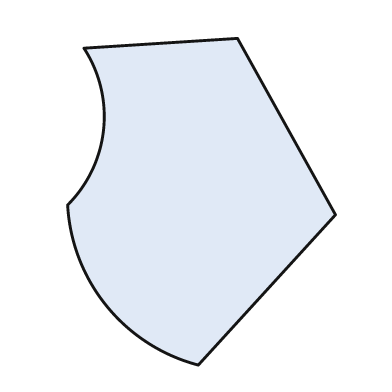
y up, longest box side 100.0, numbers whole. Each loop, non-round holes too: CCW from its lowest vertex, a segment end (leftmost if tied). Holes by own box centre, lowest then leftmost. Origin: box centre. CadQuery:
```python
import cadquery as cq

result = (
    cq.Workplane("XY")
    .moveTo(-1.0, -50.0)
    .lineTo(41.0, -4.0)
    .lineTo(11.0, 50.0)
    .lineTo(-36.0, 47.0)
    .threePointArc((-30.0, 22.0), (-41.0, -1.0))
    .threePointArc((-29.0, -32.0), (-1.0, -50.0))
    .close()
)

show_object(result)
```